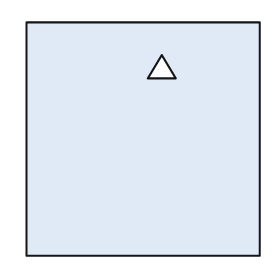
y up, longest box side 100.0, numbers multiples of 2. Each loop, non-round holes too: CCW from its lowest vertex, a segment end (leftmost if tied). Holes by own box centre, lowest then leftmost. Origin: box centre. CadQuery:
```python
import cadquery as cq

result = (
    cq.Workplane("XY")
    .moveTo(-50.0, -50.0)
    .lineTo(50.0, -50.0)
    .lineTo(50.0, 50.0)
    .lineTo(-50.0, 50.0)
    .close()
    .moveTo(2.0, 26.0)
    .lineTo(14.0, 26.0)
    .lineTo(8.0, 36.0)
    .close()
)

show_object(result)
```